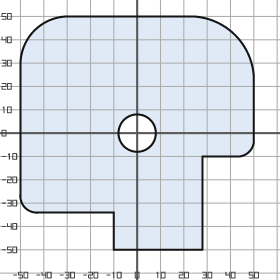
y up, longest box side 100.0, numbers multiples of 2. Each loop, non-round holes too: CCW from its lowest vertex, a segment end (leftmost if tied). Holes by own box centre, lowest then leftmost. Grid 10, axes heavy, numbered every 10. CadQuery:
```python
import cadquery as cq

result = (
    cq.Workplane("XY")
    .moveTo(-10.0, -50.0)
    .lineTo(28.0, -50.0)
    .lineTo(28.0, -10.0)
    .lineTo(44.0, -10.0)
    .threePointArc((48.0, -8.0), (50.0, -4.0))
    .lineTo(50.0, 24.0)
    .threePointArc((42.0, 42.0), (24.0, 50.0))
    .lineTo(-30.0, 50.0)
    .threePointArc((-44.0, 44.0), (-50.0, 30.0))
    .lineTo(-50.0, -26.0)
    .threePointArc((-48.0, -32.0), (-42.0, -34.0))
    .lineTo(-10.0, -34.0)
    .close()
    .moveTo(0.0, 0.0)
    .circle(8.0)
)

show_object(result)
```